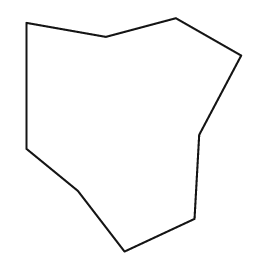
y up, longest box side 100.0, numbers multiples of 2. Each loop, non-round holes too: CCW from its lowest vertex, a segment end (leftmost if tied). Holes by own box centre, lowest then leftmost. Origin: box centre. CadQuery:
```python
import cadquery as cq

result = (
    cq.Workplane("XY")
    .moveTo(-4.0, -50.0)
    .lineTo(26.0, -36.0)
    .lineTo(28.0, 0.0)
    .lineTo(46.0, 34.0)
    .lineTo(18.0, 50.0)
    .lineTo(-12.0, 42.0)
    .lineTo(-46.0, 48.0)
    .lineTo(-46.0, -6.0)
    .lineTo(-24.0, -24.0)
    .close()
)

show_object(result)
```